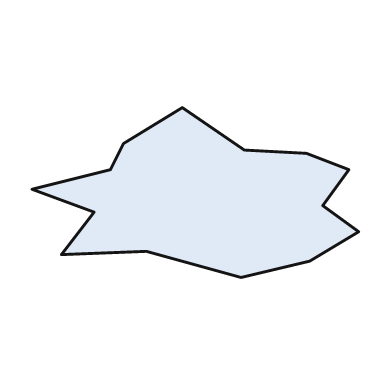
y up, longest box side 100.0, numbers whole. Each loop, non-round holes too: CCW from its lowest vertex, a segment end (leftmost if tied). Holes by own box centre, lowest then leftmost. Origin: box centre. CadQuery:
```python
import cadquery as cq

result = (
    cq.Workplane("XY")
    .moveTo(14.0, -26.0)
    .lineTo(35.0, -21.0)
    .lineTo(50.0, -12.0)
    .lineTo(39.0, -4.0)
    .lineTo(47.0, 7.0)
    .lineTo(34.0, 12.0)
    .lineTo(15.0, 13.0)
    .lineTo(-4.0, 26.0)
    .lineTo(-22.0, 15.0)
    .lineTo(-26.0, 7.0)
    .lineTo(-50.0, 1.0)
    .lineTo(-31.0, -6.0)
    .lineTo(-41.0, -19.0)
    .lineTo(-15.0, -18.0)
    .close()
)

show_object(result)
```